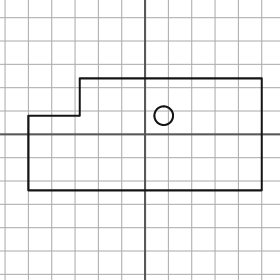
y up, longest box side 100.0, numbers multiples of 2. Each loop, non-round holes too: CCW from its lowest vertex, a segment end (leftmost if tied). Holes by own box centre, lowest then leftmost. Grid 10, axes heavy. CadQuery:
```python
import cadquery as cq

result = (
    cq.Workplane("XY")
    .moveTo(-50.0, -24.0)
    .lineTo(50.0, -24.0)
    .lineTo(50.0, 24.0)
    .lineTo(-28.0, 24.0)
    .lineTo(-28.0, 8.0)
    .lineTo(-50.0, 8.0)
    .close()
    .moveTo(8.0, 8.0)
    .circle(4.0)
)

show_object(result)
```